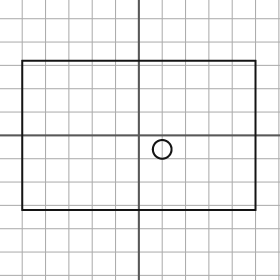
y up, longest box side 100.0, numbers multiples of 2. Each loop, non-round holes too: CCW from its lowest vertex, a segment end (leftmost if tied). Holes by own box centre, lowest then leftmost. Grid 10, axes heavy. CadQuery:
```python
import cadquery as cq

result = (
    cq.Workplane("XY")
    .moveTo(-50.0, -32.0)
    .lineTo(50.0, -32.0)
    .lineTo(50.0, 32.0)
    .lineTo(-50.0, 32.0)
    .close()
    .moveTo(10.0, -6.0)
    .circle(4.0)
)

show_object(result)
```